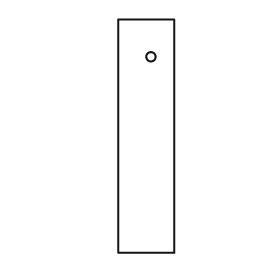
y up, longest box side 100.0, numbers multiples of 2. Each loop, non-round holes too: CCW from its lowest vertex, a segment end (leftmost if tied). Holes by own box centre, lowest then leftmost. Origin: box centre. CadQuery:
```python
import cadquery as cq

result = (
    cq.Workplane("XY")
    .moveTo(-12.0, -50.0)
    .lineTo(12.0, -50.0)
    .lineTo(12.0, 50.0)
    .lineTo(-12.0, 50.0)
    .close()
    .moveTo(2.0, 34.0)
    .circle(2.0)
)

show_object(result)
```